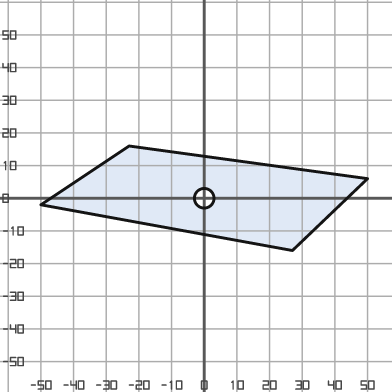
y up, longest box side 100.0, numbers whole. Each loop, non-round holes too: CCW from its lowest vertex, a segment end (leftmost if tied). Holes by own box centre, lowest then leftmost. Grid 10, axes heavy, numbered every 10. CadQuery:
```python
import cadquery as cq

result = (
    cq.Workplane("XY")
    .moveTo(27.0, -16.0)
    .lineTo(50.0, 6.0)
    .lineTo(-23.0, 16.0)
    .lineTo(-50.0, -2.0)
    .close()
    .moveTo(0.0, 0.0)
    .circle(3.0)
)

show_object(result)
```